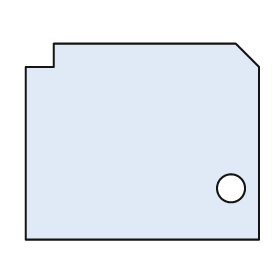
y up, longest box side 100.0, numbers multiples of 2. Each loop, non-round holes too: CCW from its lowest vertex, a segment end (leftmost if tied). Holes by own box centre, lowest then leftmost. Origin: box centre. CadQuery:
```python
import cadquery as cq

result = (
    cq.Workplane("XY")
    .moveTo(-50.0, -42.0)
    .lineTo(50.0, -42.0)
    .lineTo(50.0, 32.0)
    .lineTo(40.0, 42.0)
    .lineTo(-38.0, 42.0)
    .lineTo(-38.0, 32.0)
    .lineTo(-50.0, 32.0)
    .close()
    .moveTo(38.0, -20.0)
    .circle(6.0)
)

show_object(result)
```